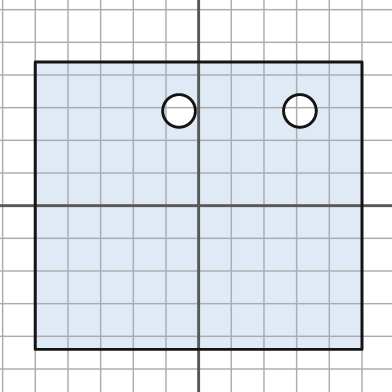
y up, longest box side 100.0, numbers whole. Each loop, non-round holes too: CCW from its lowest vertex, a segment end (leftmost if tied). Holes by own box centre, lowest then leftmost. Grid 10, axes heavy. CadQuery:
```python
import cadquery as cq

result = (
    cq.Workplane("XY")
    .moveTo(-50.0, -44.0)
    .lineTo(50.0, -44.0)
    .lineTo(50.0, 44.0)
    .lineTo(-50.0, 44.0)
    .close()
    .moveTo(-6.0, 29.0)
    .circle(5.0)
    .moveTo(31.0, 29.0)
    .circle(5.0)
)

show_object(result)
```